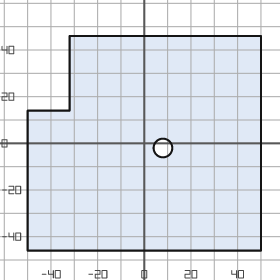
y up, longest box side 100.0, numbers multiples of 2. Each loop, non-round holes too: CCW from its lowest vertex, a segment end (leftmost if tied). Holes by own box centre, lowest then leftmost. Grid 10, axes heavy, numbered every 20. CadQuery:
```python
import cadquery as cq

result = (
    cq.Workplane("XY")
    .moveTo(-50.0, -46.0)
    .lineTo(50.0, -46.0)
    .lineTo(50.0, 46.0)
    .lineTo(-32.0, 46.0)
    .lineTo(-32.0, 14.0)
    .lineTo(-50.0, 14.0)
    .close()
    .moveTo(8.0, -2.0)
    .circle(4.0)
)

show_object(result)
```